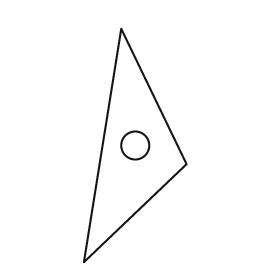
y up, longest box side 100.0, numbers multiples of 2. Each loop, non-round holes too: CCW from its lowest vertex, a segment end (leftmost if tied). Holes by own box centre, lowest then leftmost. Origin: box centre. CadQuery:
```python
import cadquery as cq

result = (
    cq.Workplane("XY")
    .moveTo(-22.0, -50.0)
    .lineTo(22.0, -8.0)
    .lineTo(-6.0, 50.0)
    .close()
    .moveTo(0.0, 0.0)
    .circle(6.0)
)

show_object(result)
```